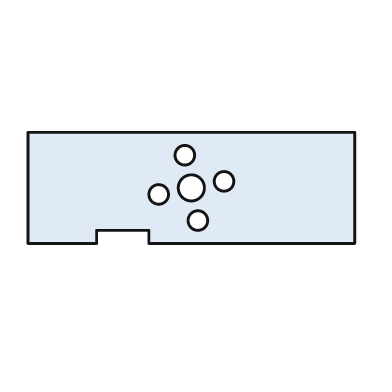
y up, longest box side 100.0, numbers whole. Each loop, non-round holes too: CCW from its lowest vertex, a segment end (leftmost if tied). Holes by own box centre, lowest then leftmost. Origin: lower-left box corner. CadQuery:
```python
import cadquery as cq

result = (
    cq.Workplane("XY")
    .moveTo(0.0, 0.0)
    .lineTo(21.0, 0.0)
    .lineTo(21.0, 4.0)
    .lineTo(37.0, 4.0)
    .lineTo(37.0, 0.0)
    .lineTo(100.0, 0.0)
    .lineTo(100.0, 34.0)
    .lineTo(0.0, 34.0)
    .close()
    .moveTo(52.0, 7.0)
    .circle(3.0)
    .moveTo(40.0, 15.0)
    .circle(3.0)
    .moveTo(50.0, 17.0)
    .circle(4.0)
    .moveTo(60.0, 19.0)
    .circle(3.0)
    .moveTo(48.0, 27.0)
    .circle(3.0)
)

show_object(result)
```